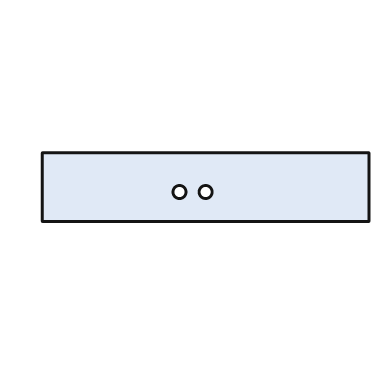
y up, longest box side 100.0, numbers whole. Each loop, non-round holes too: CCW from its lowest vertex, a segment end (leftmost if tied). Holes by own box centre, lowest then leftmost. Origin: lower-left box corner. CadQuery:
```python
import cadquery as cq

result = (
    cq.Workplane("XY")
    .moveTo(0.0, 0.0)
    .lineTo(100.0, 0.0)
    .lineTo(100.0, 21.0)
    .lineTo(0.0, 21.0)
    .close()
    .moveTo(42.0, 9.0)
    .circle(2.0)
    .moveTo(50.0, 9.0)
    .circle(2.0)
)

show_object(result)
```